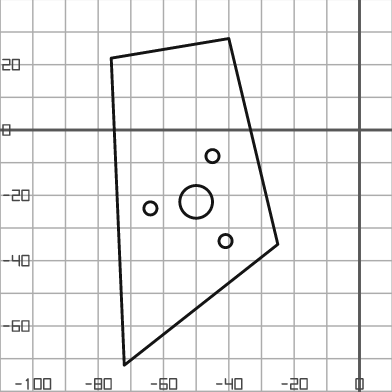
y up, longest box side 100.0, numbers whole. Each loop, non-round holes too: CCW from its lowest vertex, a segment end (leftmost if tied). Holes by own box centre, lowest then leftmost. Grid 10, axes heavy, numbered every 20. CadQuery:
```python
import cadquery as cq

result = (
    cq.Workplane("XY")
    .moveTo(-72.0, -72.0)
    .lineTo(-25.0, -35.0)
    .lineTo(-40.0, 28.0)
    .lineTo(-76.0, 22.0)
    .close()
    .moveTo(-41.0, -34.0)
    .circle(2.0)
    .moveTo(-64.0, -24.0)
    .circle(2.0)
    .moveTo(-50.0, -22.0)
    .circle(5.0)
    .moveTo(-45.0, -8.0)
    .circle(2.0)
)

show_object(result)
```